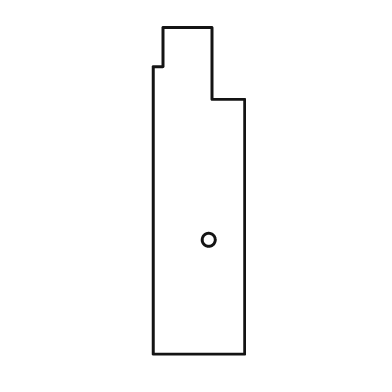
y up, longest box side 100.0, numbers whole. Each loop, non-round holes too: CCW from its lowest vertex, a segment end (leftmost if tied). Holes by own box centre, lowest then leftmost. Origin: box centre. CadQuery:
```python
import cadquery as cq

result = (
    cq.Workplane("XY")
    .moveTo(-14.0, -50.0)
    .lineTo(14.0, -50.0)
    .lineTo(14.0, 28.0)
    .lineTo(4.0, 28.0)
    .lineTo(4.0, 50.0)
    .lineTo(-11.0, 50.0)
    .lineTo(-11.0, 38.0)
    .lineTo(-14.0, 38.0)
    .close()
    .moveTo(3.0, -15.0)
    .circle(2.0)
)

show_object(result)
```